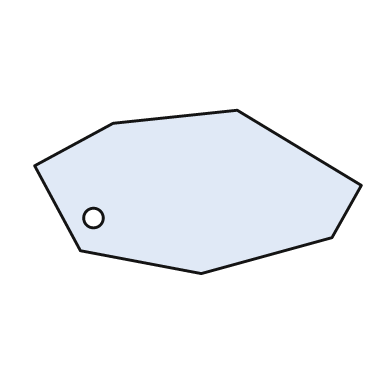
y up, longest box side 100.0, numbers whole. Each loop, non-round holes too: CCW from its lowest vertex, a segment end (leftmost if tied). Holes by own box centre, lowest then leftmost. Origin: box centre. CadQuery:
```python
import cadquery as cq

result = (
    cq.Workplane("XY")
    .moveTo(1.0, -25.0)
    .lineTo(41.0, -14.0)
    .lineTo(50.0, 2.0)
    .lineTo(12.0, 25.0)
    .lineTo(-26.0, 21.0)
    .lineTo(-50.0, 8.0)
    .lineTo(-36.0, -18.0)
    .close()
    .moveTo(-32.0, -8.0)
    .circle(3.0)
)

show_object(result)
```